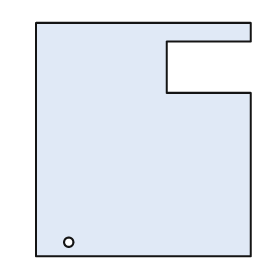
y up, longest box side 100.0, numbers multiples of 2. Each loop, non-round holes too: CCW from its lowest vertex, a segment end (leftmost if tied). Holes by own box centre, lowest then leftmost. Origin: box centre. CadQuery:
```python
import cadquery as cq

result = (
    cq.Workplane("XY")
    .moveTo(-46.0, -50.0)
    .lineTo(46.0, -50.0)
    .lineTo(46.0, 20.0)
    .lineTo(10.0, 20.0)
    .lineTo(10.0, 42.0)
    .lineTo(46.0, 42.0)
    .lineTo(46.0, 50.0)
    .lineTo(-46.0, 50.0)
    .close()
    .moveTo(-32.0, -44.0)
    .circle(2.0)
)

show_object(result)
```